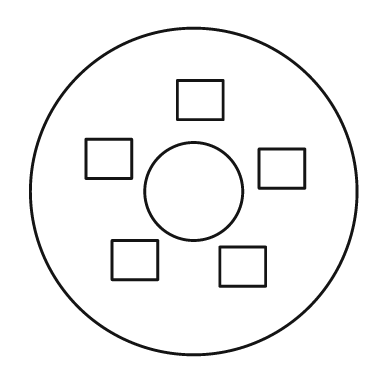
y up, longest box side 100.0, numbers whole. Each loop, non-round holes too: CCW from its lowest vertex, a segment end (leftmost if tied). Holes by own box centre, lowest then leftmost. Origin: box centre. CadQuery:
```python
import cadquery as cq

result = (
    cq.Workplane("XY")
    .moveTo(0.0, 0.0)
    .circle(50.0)
    .moveTo(8.0, -29.0)
    .lineTo(22.0, -29.0)
    .lineTo(22.0, -17.0)
    .lineTo(8.0, -17.0)
    .close()
    .moveTo(-25.0, -27.0)
    .lineTo(-11.0, -27.0)
    .lineTo(-11.0, -15.0)
    .lineTo(-25.0, -15.0)
    .close()
    .moveTo(0.0, 0.0)
    .circle(15.0)
    .moveTo(20.0, 1.0)
    .lineTo(34.0, 1.0)
    .lineTo(34.0, 13.0)
    .lineTo(20.0, 13.0)
    .close()
    .moveTo(-33.0, 4.0)
    .lineTo(-19.0, 4.0)
    .lineTo(-19.0, 16.0)
    .lineTo(-33.0, 16.0)
    .close()
    .moveTo(-5.0, 22.0)
    .lineTo(9.0, 22.0)
    .lineTo(9.0, 34.0)
    .lineTo(-5.0, 34.0)
    .close()
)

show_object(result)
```